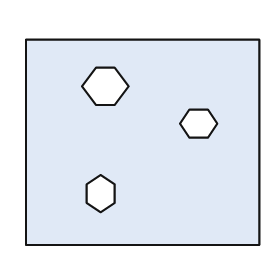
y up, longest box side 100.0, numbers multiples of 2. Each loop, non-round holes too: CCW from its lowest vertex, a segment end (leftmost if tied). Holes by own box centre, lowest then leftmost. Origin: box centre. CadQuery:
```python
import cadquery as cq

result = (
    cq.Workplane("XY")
    .moveTo(-50.0, -44.0)
    .lineTo(50.0, -44.0)
    .lineTo(50.0, 44.0)
    .lineTo(-50.0, 44.0)
    .close()
    .moveTo(-18.0, -30.0)
    .lineTo(-12.0, -26.0)
    .lineTo(-12.0, -18.0)
    .lineTo(-18.0, -14.0)
    .lineTo(-24.0, -18.0)
    .lineTo(-24.0, -26.0)
    .close()
    .moveTo(20.0, 2.0)
    .lineTo(28.0, 2.0)
    .lineTo(32.0, 8.0)
    .lineTo(28.0, 14.0)
    .lineTo(20.0, 14.0)
    .lineTo(16.0, 8.0)
    .close()
    .moveTo(-20.0, 16.0)
    .lineTo(-12.0, 16.0)
    .lineTo(-6.0, 24.0)
    .lineTo(-12.0, 32.0)
    .lineTo(-20.0, 32.0)
    .lineTo(-26.0, 24.0)
    .close()
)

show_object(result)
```